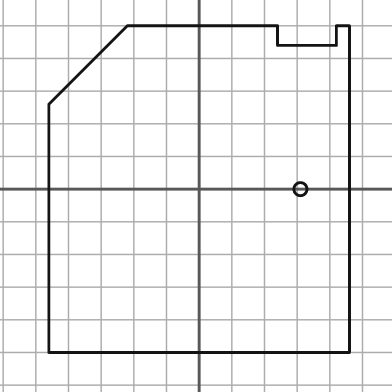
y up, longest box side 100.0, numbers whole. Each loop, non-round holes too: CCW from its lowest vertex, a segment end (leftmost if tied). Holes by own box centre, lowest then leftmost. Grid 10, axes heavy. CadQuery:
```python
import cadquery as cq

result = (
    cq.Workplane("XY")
    .moveTo(-46.0, -50.0)
    .lineTo(46.0, -50.0)
    .lineTo(46.0, 50.0)
    .lineTo(42.0, 50.0)
    .lineTo(42.0, 44.0)
    .lineTo(24.0, 44.0)
    .lineTo(24.0, 50.0)
    .lineTo(-22.0, 50.0)
    .lineTo(-46.0, 26.0)
    .close()
    .moveTo(31.0, 0.0)
    .circle(2.0)
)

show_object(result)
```